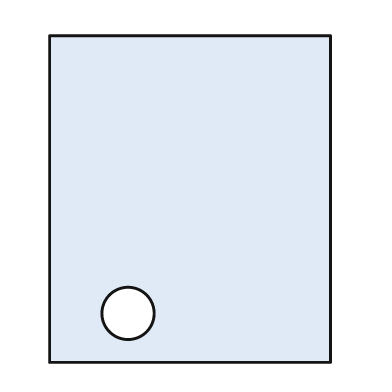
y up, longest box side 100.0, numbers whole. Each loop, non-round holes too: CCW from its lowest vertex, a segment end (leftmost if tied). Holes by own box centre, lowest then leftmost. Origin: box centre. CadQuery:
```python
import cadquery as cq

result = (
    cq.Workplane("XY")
    .moveTo(-43.0, -50.0)
    .lineTo(43.0, -50.0)
    .lineTo(43.0, 50.0)
    .lineTo(-43.0, 50.0)
    .close()
    .moveTo(-19.0, -35.0)
    .circle(8.0)
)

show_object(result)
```